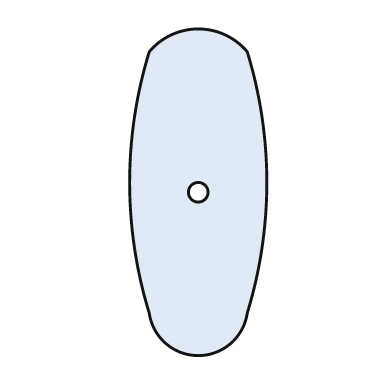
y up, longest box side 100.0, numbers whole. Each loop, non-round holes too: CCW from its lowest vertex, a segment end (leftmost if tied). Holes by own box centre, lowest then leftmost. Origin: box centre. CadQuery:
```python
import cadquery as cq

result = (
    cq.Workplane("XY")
    .moveTo(-15.0, -37.0)
    .threePointArc((0.0, -50.0), (15.0, -37.0))
    .threePointArc((21.0, 3.0), (15.0, 43.0))
    .threePointArc((0.0, 50.0), (-15.0, 43.0))
    .threePointArc((-21.0, 3.0), (-15.0, -37.0))
    .close()
    .moveTo(0.0, 0.0)
    .circle(3.0)
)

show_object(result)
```